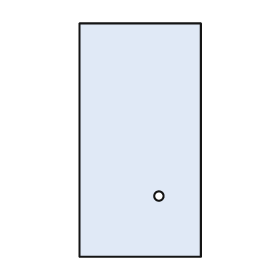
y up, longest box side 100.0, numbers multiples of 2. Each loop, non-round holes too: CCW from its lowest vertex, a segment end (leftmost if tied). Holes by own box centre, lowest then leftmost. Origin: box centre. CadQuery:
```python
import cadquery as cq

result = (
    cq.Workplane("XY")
    .moveTo(-26.0, -50.0)
    .lineTo(26.0, -50.0)
    .lineTo(26.0, 50.0)
    .lineTo(-26.0, 50.0)
    .close()
    .moveTo(8.0, -24.0)
    .circle(2.0)
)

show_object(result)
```